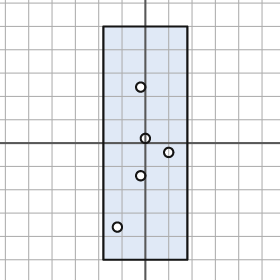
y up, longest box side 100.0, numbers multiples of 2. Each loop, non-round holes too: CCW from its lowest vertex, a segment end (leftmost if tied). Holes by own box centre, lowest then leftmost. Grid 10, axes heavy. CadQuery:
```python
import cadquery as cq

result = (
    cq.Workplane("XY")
    .moveTo(-18.0, -50.0)
    .lineTo(18.0, -50.0)
    .lineTo(18.0, 50.0)
    .lineTo(-18.0, 50.0)
    .close()
    .moveTo(-12.0, -36.0)
    .circle(2.0)
    .moveTo(-2.0, -14.0)
    .circle(2.0)
    .moveTo(10.0, -4.0)
    .circle(2.0)
    .moveTo(0.0, 2.0)
    .circle(2.0)
    .moveTo(-2.0, 24.0)
    .circle(2.0)
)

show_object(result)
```